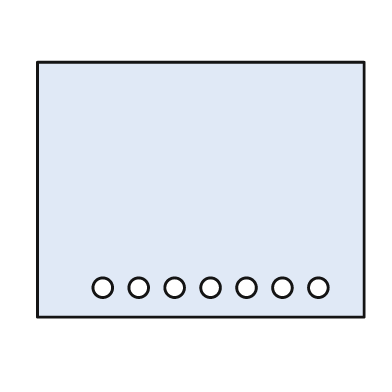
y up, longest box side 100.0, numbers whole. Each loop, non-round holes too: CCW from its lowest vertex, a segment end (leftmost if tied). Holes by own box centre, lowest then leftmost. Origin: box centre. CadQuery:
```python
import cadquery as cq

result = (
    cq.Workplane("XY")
    .moveTo(-50.0, -39.0)
    .lineTo(50.0, -39.0)
    .lineTo(50.0, 39.0)
    .lineTo(-50.0, 39.0)
    .close()
    .moveTo(-30.0, -30.0)
    .circle(3.0)
    .moveTo(-19.0, -30.0)
    .circle(3.0)
    .moveTo(-8.0, -30.0)
    .circle(3.0)
    .moveTo(3.0, -30.0)
    .circle(3.0)
    .moveTo(14.0, -30.0)
    .circle(3.0)
    .moveTo(25.0, -30.0)
    .circle(3.0)
    .moveTo(36.0, -30.0)
    .circle(3.0)
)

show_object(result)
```